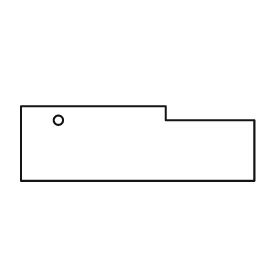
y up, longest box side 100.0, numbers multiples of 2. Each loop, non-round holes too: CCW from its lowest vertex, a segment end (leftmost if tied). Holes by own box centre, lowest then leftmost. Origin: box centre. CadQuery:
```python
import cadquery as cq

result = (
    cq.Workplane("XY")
    .moveTo(-50.0, -16.0)
    .lineTo(50.0, -16.0)
    .lineTo(50.0, 10.0)
    .lineTo(12.0, 10.0)
    .lineTo(12.0, 16.0)
    .lineTo(-50.0, 16.0)
    .close()
    .moveTo(-34.0, 10.0)
    .circle(2.0)
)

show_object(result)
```